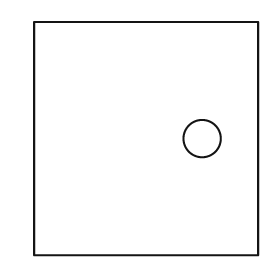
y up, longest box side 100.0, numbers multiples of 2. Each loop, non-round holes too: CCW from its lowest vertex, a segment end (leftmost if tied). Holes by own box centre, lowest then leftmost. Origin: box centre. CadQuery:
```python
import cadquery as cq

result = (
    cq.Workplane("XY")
    .moveTo(-48.0, -50.0)
    .lineTo(48.0, -50.0)
    .lineTo(48.0, 50.0)
    .lineTo(-48.0, 50.0)
    .close()
    .moveTo(24.0, 0.0)
    .circle(8.0)
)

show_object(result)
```